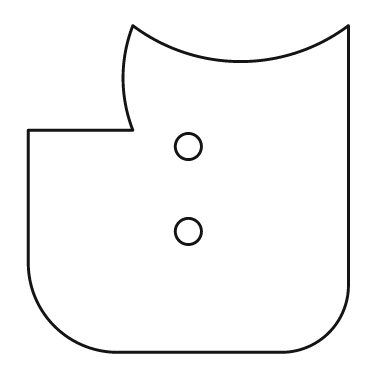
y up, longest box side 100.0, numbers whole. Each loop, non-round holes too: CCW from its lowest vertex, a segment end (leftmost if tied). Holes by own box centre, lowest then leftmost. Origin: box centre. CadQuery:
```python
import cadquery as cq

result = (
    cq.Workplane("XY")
    .moveTo(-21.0, -50.0)
    .lineTo(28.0, -50.0)
    .threePointArc((43.0, -44.0), (49.0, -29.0))
    .lineTo(49.0, 50.0)
    .threePointArc((16.0, 39.0), (-17.0, 50.0))
    .threePointArc((-20.0, 34.0), (-17.0, 18.0))
    .lineTo(-49.0, 18.0)
    .lineTo(-49.0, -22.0)
    .threePointArc((-41.0, -42.0), (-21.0, -50.0))
    .close()
    .moveTo(0.0, -13.0)
    .circle(4.0)
    .moveTo(0.0, 13.0)
    .circle(4.0)
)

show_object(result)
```